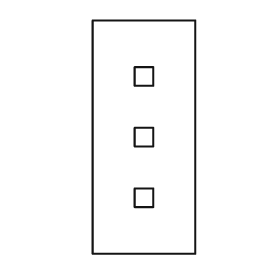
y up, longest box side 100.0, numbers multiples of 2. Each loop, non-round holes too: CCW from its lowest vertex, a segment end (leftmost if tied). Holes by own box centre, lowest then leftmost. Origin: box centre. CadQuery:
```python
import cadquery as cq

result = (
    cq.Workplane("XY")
    .moveTo(-22.0, -50.0)
    .lineTo(22.0, -50.0)
    .lineTo(22.0, 50.0)
    .lineTo(-22.0, 50.0)
    .close()
    .moveTo(-4.0, -30.0)
    .lineTo(4.0, -30.0)
    .lineTo(4.0, -22.0)
    .lineTo(-4.0, -22.0)
    .close()
    .moveTo(-4.0, -4.0)
    .lineTo(4.0, -4.0)
    .lineTo(4.0, 4.0)
    .lineTo(-4.0, 4.0)
    .close()
    .moveTo(-4.0, 22.0)
    .lineTo(4.0, 22.0)
    .lineTo(4.0, 30.0)
    .lineTo(-4.0, 30.0)
    .close()
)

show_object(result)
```